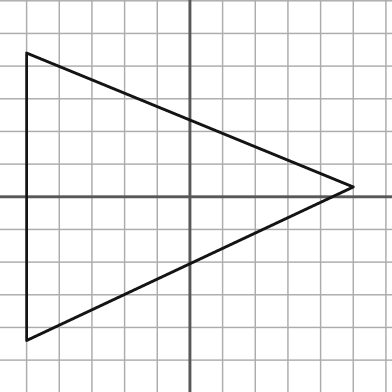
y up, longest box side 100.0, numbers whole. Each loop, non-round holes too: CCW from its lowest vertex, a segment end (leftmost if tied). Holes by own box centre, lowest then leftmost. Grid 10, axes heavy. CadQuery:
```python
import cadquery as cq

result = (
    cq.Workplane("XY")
    .moveTo(-50.0, -44.0)
    .lineTo(50.0, 3.0)
    .lineTo(-50.0, 44.0)
    .close()
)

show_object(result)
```